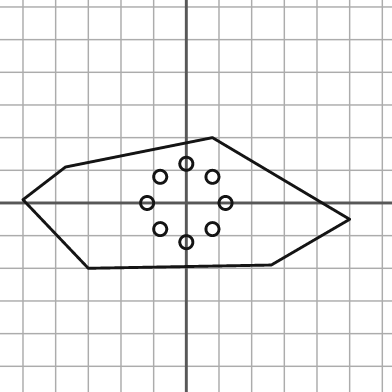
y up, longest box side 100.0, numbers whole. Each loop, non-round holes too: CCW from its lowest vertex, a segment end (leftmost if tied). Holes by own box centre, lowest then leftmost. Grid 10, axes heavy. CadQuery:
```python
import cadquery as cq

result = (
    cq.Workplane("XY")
    .moveTo(-30.0, -20.0)
    .lineTo(26.0, -19.0)
    .lineTo(50.0, -5.0)
    .lineTo(8.0, 20.0)
    .lineTo(-37.0, 11.0)
    .lineTo(-50.0, 1.0)
    .close()
    .moveTo(0.0, -12.0)
    .circle(2.0)
    .moveTo(-8.0, -8.0)
    .circle(2.0)
    .moveTo(8.0, -8.0)
    .circle(2.0)
    .moveTo(-12.0, 0.0)
    .circle(2.0)
    .moveTo(12.0, 0.0)
    .circle(2.0)
    .moveTo(-8.0, 8.0)
    .circle(2.0)
    .moveTo(8.0, 8.0)
    .circle(2.0)
    .moveTo(0.0, 12.0)
    .circle(2.0)
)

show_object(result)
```